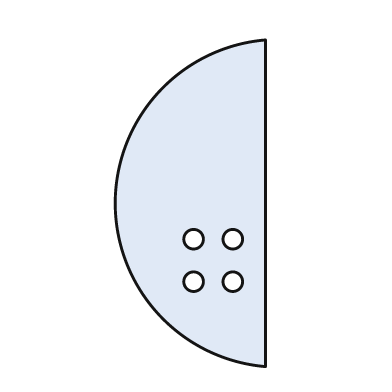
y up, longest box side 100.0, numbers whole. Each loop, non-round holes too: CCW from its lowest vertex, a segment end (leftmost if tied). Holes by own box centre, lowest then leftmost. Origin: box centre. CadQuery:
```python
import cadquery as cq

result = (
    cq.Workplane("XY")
    .moveTo(23.0, -50.0)
    .lineTo(23.0, 50.0)
    .threePointArc((-23.0, 0.0), (23.0, -50.0))
    .close()
    .moveTo(1.0, -24.0)
    .circle(3.0)
    .moveTo(13.0, -24.0)
    .circle(3.0)
    .moveTo(1.0, -11.0)
    .circle(3.0)
    .moveTo(13.0, -11.0)
    .circle(3.0)
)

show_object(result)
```